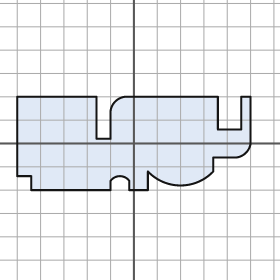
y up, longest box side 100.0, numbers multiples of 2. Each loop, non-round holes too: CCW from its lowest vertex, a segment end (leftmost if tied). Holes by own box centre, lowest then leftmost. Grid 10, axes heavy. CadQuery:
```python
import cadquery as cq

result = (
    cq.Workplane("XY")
    .moveTo(-44.0, -20.0)
    .lineTo(-10.0, -20.0)
    .lineTo(-10.0, -16.0)
    .threePointArc((-6.0, -14.0), (-2.0, -16.0))
    .lineTo(-2.0, -20.0)
    .lineTo(6.0, -20.0)
    .lineTo(6.0, -12.0)
    .threePointArc((20.0, -18.0), (34.0, -12.0))
    .lineTo(34.0, -6.0)
    .lineTo(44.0, -6.0)
    .threePointArc((48.0, -4.0), (50.0, 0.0))
    .lineTo(50.0, 20.0)
    .lineTo(46.0, 20.0)
    .lineTo(46.0, 6.0)
    .lineTo(36.0, 6.0)
    .lineTo(36.0, 20.0)
    .lineTo(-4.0, 20.0)
    .threePointArc((-8.0, 18.0), (-10.0, 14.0))
    .lineTo(-10.0, 2.0)
    .lineTo(-16.0, 2.0)
    .lineTo(-16.0, 20.0)
    .lineTo(-50.0, 20.0)
    .lineTo(-50.0, -14.0)
    .lineTo(-44.0, -14.0)
    .close()
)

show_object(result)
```